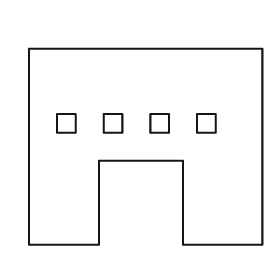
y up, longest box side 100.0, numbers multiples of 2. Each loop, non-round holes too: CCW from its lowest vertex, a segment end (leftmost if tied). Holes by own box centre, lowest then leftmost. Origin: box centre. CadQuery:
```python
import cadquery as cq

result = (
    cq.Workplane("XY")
    .moveTo(-50.0, -42.0)
    .lineTo(-20.0, -42.0)
    .lineTo(-20.0, -6.0)
    .lineTo(16.0, -6.0)
    .lineTo(16.0, -42.0)
    .lineTo(50.0, -42.0)
    .lineTo(50.0, 42.0)
    .lineTo(-50.0, 42.0)
    .close()
    .moveTo(-38.0, 6.0)
    .lineTo(-30.0, 6.0)
    .lineTo(-30.0, 14.0)
    .lineTo(-38.0, 14.0)
    .close()
    .moveTo(-18.0, 6.0)
    .lineTo(-10.0, 6.0)
    .lineTo(-10.0, 14.0)
    .lineTo(-18.0, 14.0)
    .close()
    .moveTo(2.0, 6.0)
    .lineTo(10.0, 6.0)
    .lineTo(10.0, 14.0)
    .lineTo(2.0, 14.0)
    .close()
    .moveTo(22.0, 6.0)
    .lineTo(30.0, 6.0)
    .lineTo(30.0, 14.0)
    .lineTo(22.0, 14.0)
    .close()
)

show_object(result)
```